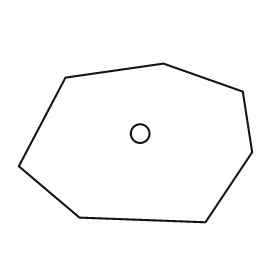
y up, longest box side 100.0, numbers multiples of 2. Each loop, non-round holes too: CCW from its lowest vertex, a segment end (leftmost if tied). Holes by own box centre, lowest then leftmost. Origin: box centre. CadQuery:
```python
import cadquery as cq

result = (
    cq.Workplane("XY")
    .moveTo(30.0, -34.0)
    .lineTo(50.0, -4.0)
    .lineTo(46.0, 22.0)
    .lineTo(12.0, 34.0)
    .lineTo(-30.0, 28.0)
    .lineTo(-50.0, -10.0)
    .lineTo(-24.0, -32.0)
    .close()
    .moveTo(2.0, 4.0)
    .circle(4.0)
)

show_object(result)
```